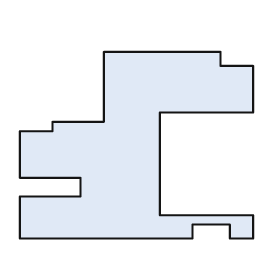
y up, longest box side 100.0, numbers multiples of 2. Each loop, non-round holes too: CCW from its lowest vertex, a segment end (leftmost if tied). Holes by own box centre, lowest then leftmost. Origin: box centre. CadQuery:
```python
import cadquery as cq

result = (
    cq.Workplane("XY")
    .moveTo(-50.0, -40.0)
    .lineTo(24.0, -40.0)
    .lineTo(24.0, -34.0)
    .lineTo(40.0, -34.0)
    .lineTo(40.0, -40.0)
    .lineTo(50.0, -40.0)
    .lineTo(50.0, -30.0)
    .lineTo(10.0, -30.0)
    .lineTo(10.0, 14.0)
    .lineTo(50.0, 14.0)
    .lineTo(50.0, 34.0)
    .lineTo(36.0, 34.0)
    .lineTo(36.0, 40.0)
    .lineTo(-14.0, 40.0)
    .lineTo(-14.0, 10.0)
    .lineTo(-36.0, 10.0)
    .lineTo(-36.0, 6.0)
    .lineTo(-50.0, 6.0)
    .lineTo(-50.0, -14.0)
    .lineTo(-24.0, -14.0)
    .lineTo(-24.0, -22.0)
    .lineTo(-50.0, -22.0)
    .close()
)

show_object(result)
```